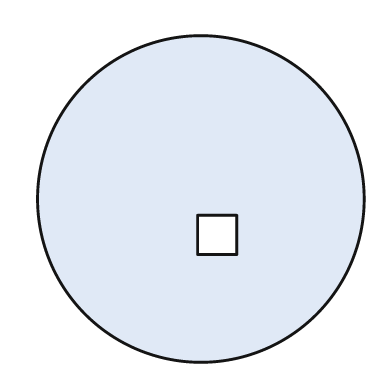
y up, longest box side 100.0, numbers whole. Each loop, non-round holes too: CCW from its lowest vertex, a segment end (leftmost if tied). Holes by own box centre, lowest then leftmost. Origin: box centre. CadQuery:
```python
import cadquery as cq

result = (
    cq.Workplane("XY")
    .moveTo(0.0, 0.0)
    .circle(50.0)
    .moveTo(-1.0, -17.0)
    .lineTo(11.0, -17.0)
    .lineTo(11.0, -5.0)
    .lineTo(-1.0, -5.0)
    .close()
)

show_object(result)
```